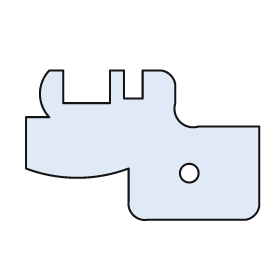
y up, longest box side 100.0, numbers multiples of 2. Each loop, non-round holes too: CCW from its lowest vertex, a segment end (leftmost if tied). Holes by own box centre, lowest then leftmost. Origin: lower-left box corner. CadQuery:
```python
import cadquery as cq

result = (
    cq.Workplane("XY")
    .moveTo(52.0, 0.0)
    .lineTo(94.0, 0.0)
    .threePointArc((98.0, 2.0), (100.0, 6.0))
    .lineTo(100.0, 40.0)
    .lineTo(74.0, 40.0)
    .threePointArc((66.0, 42.0), (64.0, 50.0))
    .lineTo(64.0, 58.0)
    .threePointArc((62.0, 62.0), (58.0, 64.0))
    .lineTo(50.0, 64.0)
    .lineTo(50.0, 52.0)
    .lineTo(42.0, 52.0)
    .lineTo(42.0, 64.0)
    .lineTo(36.0, 64.0)
    .lineTo(36.0, 50.0)
    .lineTo(16.0, 50.0)
    .lineTo(16.0, 64.0)
    .lineTo(10.0, 64.0)
    .threePointArc((6.0, 54.0), (10.0, 44.0))
    .lineTo(0.0, 44.0)
    .lineTo(0.0, 22.0)
    .threePointArc((22.0, 18.0), (44.0, 22.0))
    .lineTo(44.0, 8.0)
    .threePointArc((46.0, 2.0), (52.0, 0.0))
    .close()
    .moveTo(70.0, 20.0)
    .circle(4.0)
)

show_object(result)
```